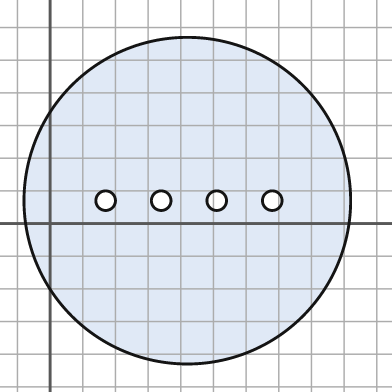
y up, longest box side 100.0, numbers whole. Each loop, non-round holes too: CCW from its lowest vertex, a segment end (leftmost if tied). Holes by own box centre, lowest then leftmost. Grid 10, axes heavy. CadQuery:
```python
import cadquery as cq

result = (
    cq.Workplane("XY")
    .moveTo(42.0, 7.0)
    .circle(50.0)
    .moveTo(17.0, 7.0)
    .circle(3.0)
    .moveTo(34.0, 7.0)
    .circle(3.0)
    .moveTo(51.0, 7.0)
    .circle(3.0)
    .moveTo(68.0, 7.0)
    .circle(3.0)
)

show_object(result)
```